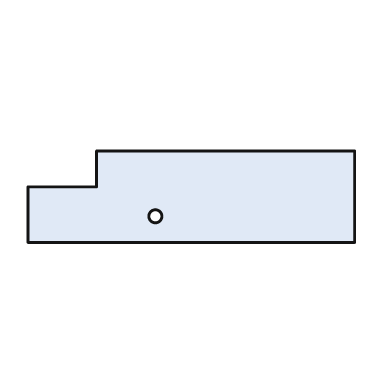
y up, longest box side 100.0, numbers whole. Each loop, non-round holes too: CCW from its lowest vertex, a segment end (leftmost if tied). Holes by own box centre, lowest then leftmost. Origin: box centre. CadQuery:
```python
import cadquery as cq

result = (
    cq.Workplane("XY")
    .moveTo(-50.0, -14.0)
    .lineTo(50.0, -14.0)
    .lineTo(50.0, 14.0)
    .lineTo(-29.0, 14.0)
    .lineTo(-29.0, 3.0)
    .lineTo(-50.0, 3.0)
    .close()
    .moveTo(-11.0, -6.0)
    .circle(2.0)
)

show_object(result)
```